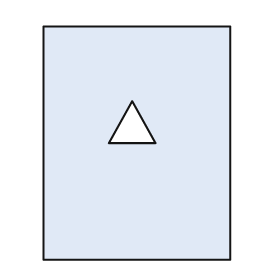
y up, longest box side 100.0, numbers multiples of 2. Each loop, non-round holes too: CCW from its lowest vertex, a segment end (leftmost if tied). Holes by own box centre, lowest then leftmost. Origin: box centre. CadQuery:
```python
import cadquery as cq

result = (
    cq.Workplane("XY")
    .moveTo(-40.0, -50.0)
    .lineTo(40.0, -50.0)
    .lineTo(40.0, 50.0)
    .lineTo(-40.0, 50.0)
    .close()
    .moveTo(-12.0, 0.0)
    .lineTo(8.0, 0.0)
    .lineTo(-2.0, 18.0)
    .close()
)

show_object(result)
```